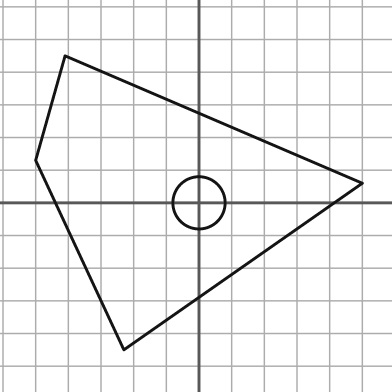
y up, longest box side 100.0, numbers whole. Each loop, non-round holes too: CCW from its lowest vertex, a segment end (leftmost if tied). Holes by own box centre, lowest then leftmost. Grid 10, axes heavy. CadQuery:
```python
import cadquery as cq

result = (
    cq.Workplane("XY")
    .moveTo(-23.0, -45.0)
    .lineTo(50.0, 6.0)
    .lineTo(-41.0, 45.0)
    .lineTo(-50.0, 13.0)
    .close()
    .moveTo(0.0, 0.0)
    .circle(8.0)
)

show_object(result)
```